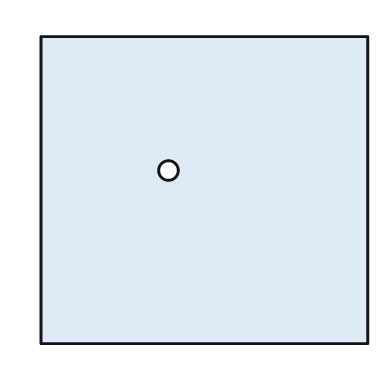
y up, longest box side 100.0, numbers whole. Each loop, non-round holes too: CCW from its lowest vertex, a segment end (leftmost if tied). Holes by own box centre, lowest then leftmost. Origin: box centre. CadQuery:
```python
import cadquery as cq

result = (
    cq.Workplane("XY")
    .moveTo(-50.0, -47.0)
    .lineTo(50.0, -47.0)
    .lineTo(50.0, 47.0)
    .lineTo(-50.0, 47.0)
    .close()
    .moveTo(-11.0, 6.0)
    .circle(3.0)
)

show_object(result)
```